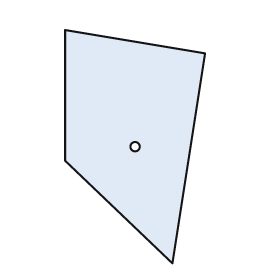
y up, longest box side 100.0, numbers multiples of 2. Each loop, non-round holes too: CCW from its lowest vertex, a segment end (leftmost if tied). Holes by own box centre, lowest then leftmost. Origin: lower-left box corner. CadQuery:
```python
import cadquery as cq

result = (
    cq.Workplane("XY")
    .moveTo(46.0, 0.0)
    .lineTo(60.0, 90.0)
    .lineTo(0.0, 100.0)
    .lineTo(0.0, 44.0)
    .close()
    .moveTo(30.0, 50.0)
    .circle(2.0)
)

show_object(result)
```